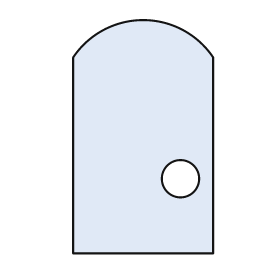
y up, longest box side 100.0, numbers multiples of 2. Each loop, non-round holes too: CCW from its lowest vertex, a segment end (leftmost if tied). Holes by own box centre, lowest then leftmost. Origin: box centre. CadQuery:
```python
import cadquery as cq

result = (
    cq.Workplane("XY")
    .moveTo(-30.0, -50.0)
    .lineTo(30.0, -50.0)
    .lineTo(30.0, 34.0)
    .threePointArc((0.0, 50.0), (-30.0, 34.0))
    .close()
    .moveTo(16.0, -18.0)
    .circle(8.0)
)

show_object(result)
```